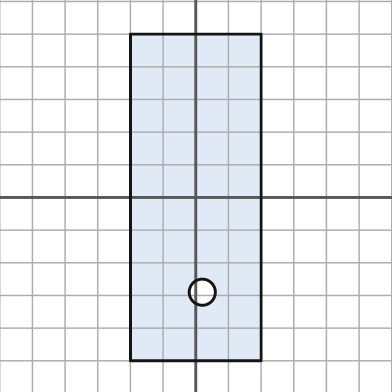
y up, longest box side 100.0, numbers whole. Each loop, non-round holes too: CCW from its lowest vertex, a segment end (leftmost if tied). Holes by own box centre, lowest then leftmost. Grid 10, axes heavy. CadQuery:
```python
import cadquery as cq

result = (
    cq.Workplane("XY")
    .moveTo(-20.0, -50.0)
    .lineTo(20.0, -50.0)
    .lineTo(20.0, 50.0)
    .lineTo(-20.0, 50.0)
    .close()
    .moveTo(2.0, -29.0)
    .circle(4.0)
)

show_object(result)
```